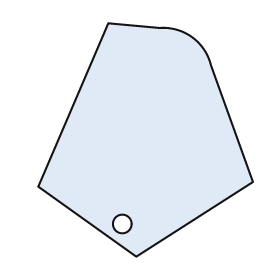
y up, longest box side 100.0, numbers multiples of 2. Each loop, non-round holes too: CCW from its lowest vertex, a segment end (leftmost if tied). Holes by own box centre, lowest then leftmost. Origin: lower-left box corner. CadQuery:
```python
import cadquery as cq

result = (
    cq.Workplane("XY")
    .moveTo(42.0, 0.0)
    .lineTo(92.0, 32.0)
    .lineTo(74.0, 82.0)
    .threePointArc((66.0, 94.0), (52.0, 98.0))
    .lineTo(30.0, 100.0)
    .lineTo(0.0, 30.0)
    .close()
    .moveTo(36.0, 14.0)
    .circle(4.0)
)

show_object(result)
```